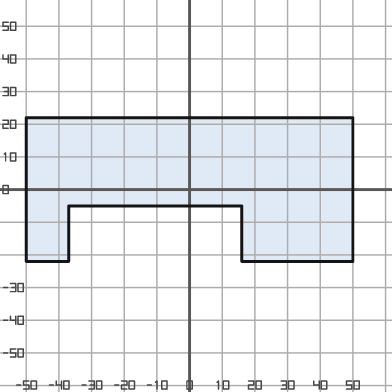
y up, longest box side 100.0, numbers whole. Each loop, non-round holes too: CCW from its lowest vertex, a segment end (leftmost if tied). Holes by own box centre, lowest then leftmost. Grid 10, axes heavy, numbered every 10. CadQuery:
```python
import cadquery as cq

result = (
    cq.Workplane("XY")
    .moveTo(-50.0, -22.0)
    .lineTo(-37.0, -22.0)
    .lineTo(-37.0, -5.0)
    .lineTo(16.0, -5.0)
    .lineTo(16.0, -22.0)
    .lineTo(50.0, -22.0)
    .lineTo(50.0, 22.0)
    .lineTo(-50.0, 22.0)
    .close()
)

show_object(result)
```